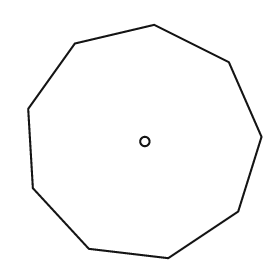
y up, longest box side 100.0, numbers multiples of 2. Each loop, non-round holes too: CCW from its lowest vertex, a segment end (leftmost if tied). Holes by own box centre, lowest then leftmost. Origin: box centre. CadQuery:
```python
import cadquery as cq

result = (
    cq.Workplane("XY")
    .moveTo(10.0, -50.0)
    .lineTo(40.0, -30.0)
    .lineTo(50.0, 2.0)
    .lineTo(36.0, 34.0)
    .lineTo(4.0, 50.0)
    .lineTo(-30.0, 42.0)
    .lineTo(-50.0, 14.0)
    .lineTo(-48.0, -20.0)
    .lineTo(-24.0, -46.0)
    .close()
    .moveTo(0.0, 0.0)
    .circle(2.0)
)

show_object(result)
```